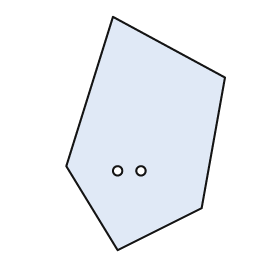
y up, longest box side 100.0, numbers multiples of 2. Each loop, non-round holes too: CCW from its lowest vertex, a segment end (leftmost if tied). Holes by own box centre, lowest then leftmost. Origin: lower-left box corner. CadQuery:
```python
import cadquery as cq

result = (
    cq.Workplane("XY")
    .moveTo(22.0, 0.0)
    .lineTo(58.0, 18.0)
    .lineTo(68.0, 74.0)
    .lineTo(20.0, 100.0)
    .lineTo(0.0, 36.0)
    .close()
    .moveTo(22.0, 34.0)
    .circle(2.0)
    .moveTo(32.0, 34.0)
    .circle(2.0)
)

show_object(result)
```